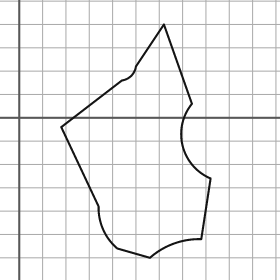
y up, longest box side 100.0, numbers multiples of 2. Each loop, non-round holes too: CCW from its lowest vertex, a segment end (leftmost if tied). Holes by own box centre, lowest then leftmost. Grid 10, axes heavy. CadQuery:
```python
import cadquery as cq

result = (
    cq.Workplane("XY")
    .moveTo(56.0, -60.0)
    .threePointArc((66.0, -54.0), (78.0, -52.0))
    .lineTo(82.0, -26.0)
    .threePointArc((70.0, -12.0), (74.0, 6.0))
    .lineTo(62.0, 40.0)
    .lineTo(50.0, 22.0)
    .threePointArc((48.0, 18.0), (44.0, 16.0))
    .lineTo(18.0, -4.0)
    .lineTo(34.0, -38.0)
    .threePointArc((36.0, -48.0), (42.0, -56.0))
    .close()
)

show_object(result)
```